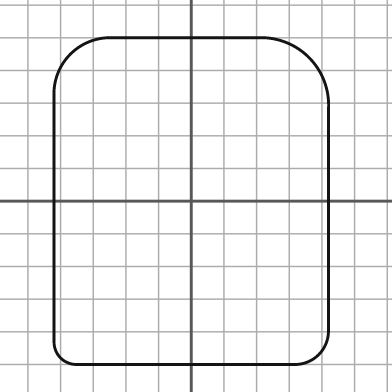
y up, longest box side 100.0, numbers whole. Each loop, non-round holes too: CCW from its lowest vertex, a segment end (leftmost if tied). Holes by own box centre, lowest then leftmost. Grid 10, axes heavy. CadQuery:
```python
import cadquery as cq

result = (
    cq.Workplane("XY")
    .moveTo(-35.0, -50.0)
    .lineTo(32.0, -50.0)
    .threePointArc((39.0, -47.0), (42.0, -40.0))
    .lineTo(42.0, 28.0)
    .threePointArc((36.0, 44.0), (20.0, 50.0))
    .lineTo(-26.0, 50.0)
    .threePointArc((-37.0, 45.0), (-42.0, 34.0))
    .lineTo(-42.0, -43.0)
    .threePointArc((-40.0, -48.0), (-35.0, -50.0))
    .close()
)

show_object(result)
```